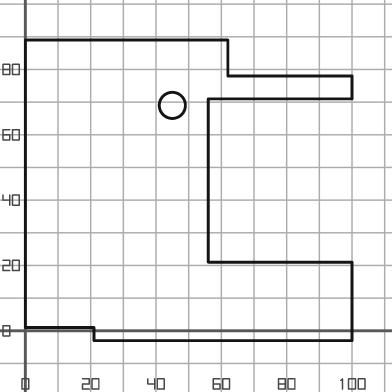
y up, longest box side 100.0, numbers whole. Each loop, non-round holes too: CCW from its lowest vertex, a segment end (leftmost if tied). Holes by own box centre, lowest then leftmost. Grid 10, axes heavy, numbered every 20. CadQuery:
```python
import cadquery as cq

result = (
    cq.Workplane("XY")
    .moveTo(21.0, -3.0)
    .lineTo(100.0, -3.0)
    .lineTo(100.0, 21.0)
    .lineTo(56.0, 21.0)
    .lineTo(56.0, 71.0)
    .lineTo(100.0, 71.0)
    .lineTo(100.0, 78.0)
    .lineTo(62.0, 78.0)
    .lineTo(62.0, 89.0)
    .lineTo(0.0, 89.0)
    .lineTo(0.0, 1.0)
    .lineTo(21.0, 1.0)
    .close()
    .moveTo(45.0, 69.0)
    .circle(4.0)
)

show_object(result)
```